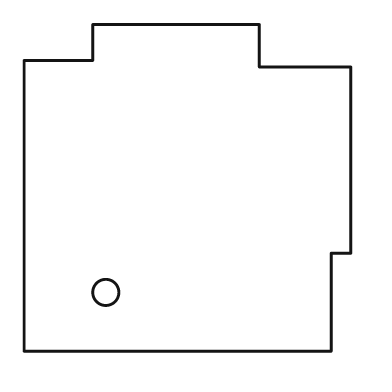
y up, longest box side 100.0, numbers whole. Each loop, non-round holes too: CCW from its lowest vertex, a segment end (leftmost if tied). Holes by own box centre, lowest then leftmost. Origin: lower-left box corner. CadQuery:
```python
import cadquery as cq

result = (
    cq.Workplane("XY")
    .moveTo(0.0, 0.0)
    .lineTo(94.0, 0.0)
    .lineTo(94.0, 30.0)
    .lineTo(100.0, 30.0)
    .lineTo(100.0, 87.0)
    .lineTo(72.0, 87.0)
    .lineTo(72.0, 100.0)
    .lineTo(21.0, 100.0)
    .lineTo(21.0, 89.0)
    .lineTo(0.0, 89.0)
    .close()
    .moveTo(25.0, 18.0)
    .circle(4.0)
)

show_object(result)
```